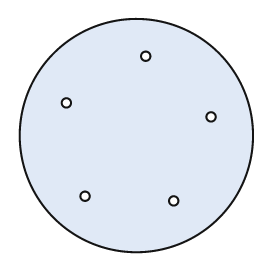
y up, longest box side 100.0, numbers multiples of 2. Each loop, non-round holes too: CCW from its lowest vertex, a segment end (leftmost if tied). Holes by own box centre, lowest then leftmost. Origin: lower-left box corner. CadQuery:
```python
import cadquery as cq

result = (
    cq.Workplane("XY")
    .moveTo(50.0, 50.0)
    .circle(50.0)
    .moveTo(66.0, 22.0)
    .circle(2.0)
    .moveTo(28.0, 24.0)
    .circle(2.0)
    .moveTo(82.0, 58.0)
    .circle(2.0)
    .moveTo(20.0, 64.0)
    .circle(2.0)
    .moveTo(54.0, 84.0)
    .circle(2.0)
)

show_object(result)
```